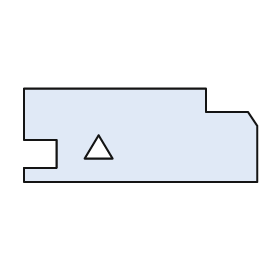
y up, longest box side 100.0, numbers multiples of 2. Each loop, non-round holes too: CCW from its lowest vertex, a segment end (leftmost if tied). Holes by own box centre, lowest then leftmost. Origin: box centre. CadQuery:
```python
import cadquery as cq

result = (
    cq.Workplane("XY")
    .moveTo(-50.0, -20.0)
    .lineTo(50.0, -20.0)
    .lineTo(50.0, 4.0)
    .lineTo(46.0, 10.0)
    .lineTo(28.0, 10.0)
    .lineTo(28.0, 20.0)
    .lineTo(-50.0, 20.0)
    .lineTo(-50.0, -2.0)
    .lineTo(-36.0, -2.0)
    .lineTo(-36.0, -14.0)
    .lineTo(-50.0, -14.0)
    .close()
    .moveTo(-24.0, -10.0)
    .lineTo(-12.0, -10.0)
    .lineTo(-18.0, 0.0)
    .close()
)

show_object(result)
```